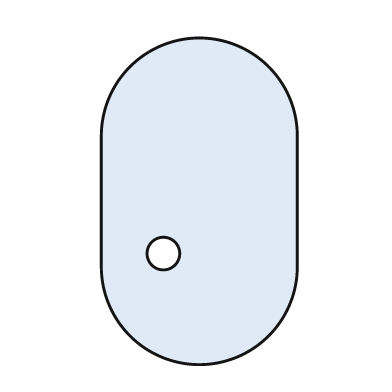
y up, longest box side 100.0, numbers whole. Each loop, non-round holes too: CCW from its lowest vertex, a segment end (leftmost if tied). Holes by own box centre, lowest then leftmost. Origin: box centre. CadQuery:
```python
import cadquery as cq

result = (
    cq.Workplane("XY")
    .moveTo(-30.0, -20.0)
    .threePointArc((0.0, -50.0), (30.0, -20.0))
    .lineTo(30.0, 20.0)
    .threePointArc((0.0, 50.0), (-30.0, 20.0))
    .close()
    .moveTo(-11.0, -16.0)
    .circle(5.0)
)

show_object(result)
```